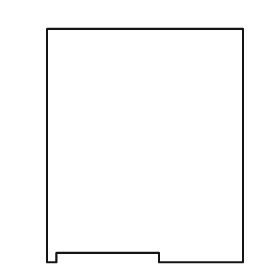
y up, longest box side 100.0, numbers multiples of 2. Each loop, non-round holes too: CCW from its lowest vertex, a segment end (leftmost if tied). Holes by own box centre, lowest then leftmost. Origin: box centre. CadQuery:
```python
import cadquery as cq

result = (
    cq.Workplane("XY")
    .moveTo(-42.0, -50.0)
    .lineTo(-38.0, -50.0)
    .lineTo(-38.0, -46.0)
    .lineTo(6.0, -46.0)
    .lineTo(6.0, -50.0)
    .lineTo(42.0, -50.0)
    .lineTo(42.0, 50.0)
    .lineTo(-42.0, 50.0)
    .close()
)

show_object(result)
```